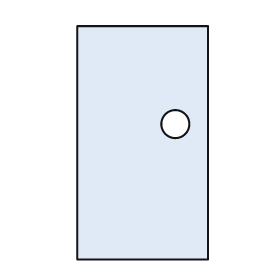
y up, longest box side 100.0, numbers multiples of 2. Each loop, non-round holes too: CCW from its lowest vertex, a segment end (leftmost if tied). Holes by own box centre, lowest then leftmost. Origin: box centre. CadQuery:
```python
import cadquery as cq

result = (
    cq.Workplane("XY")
    .moveTo(-28.0, -50.0)
    .lineTo(28.0, -50.0)
    .lineTo(28.0, 50.0)
    .lineTo(-28.0, 50.0)
    .close()
    .moveTo(14.0, 8.0)
    .circle(6.0)
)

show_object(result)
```